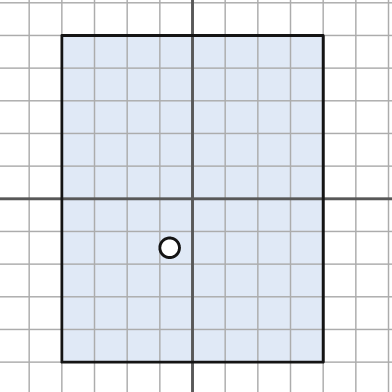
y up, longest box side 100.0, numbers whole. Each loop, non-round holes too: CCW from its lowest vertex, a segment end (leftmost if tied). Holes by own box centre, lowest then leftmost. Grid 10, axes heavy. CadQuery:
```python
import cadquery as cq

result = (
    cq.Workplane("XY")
    .moveTo(-40.0, -50.0)
    .lineTo(40.0, -50.0)
    .lineTo(40.0, 50.0)
    .lineTo(-40.0, 50.0)
    .close()
    .moveTo(-7.0, -15.0)
    .circle(3.0)
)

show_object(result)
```